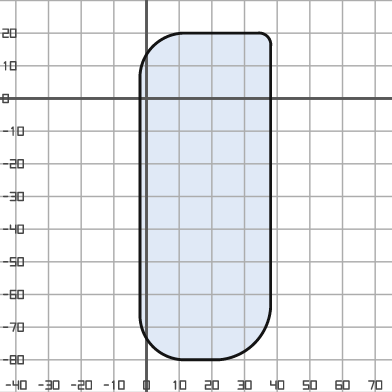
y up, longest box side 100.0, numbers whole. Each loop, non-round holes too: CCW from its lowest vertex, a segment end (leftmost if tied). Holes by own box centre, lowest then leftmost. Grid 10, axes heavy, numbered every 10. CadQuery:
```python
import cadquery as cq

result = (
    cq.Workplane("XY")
    .moveTo(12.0, -80.0)
    .lineTo(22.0, -80.0)
    .threePointArc((33.0, -75.0), (38.0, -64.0))
    .lineTo(38.0, 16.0)
    .threePointArc((37.0, 19.0), (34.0, 20.0))
    .lineTo(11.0, 20.0)
    .threePointArc((2.0, 16.0), (-2.0, 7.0))
    .lineTo(-2.0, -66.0)
    .threePointArc((2.0, -76.0), (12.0, -80.0))
    .close()
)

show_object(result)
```